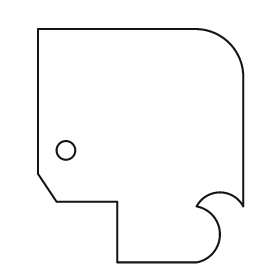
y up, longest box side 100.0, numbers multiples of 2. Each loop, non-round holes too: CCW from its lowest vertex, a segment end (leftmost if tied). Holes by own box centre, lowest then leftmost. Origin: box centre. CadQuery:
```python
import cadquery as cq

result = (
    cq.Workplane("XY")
    .moveTo(-10.0, -50.0)
    .lineTo(24.0, -50.0)
    .threePointArc((34.0, -38.0), (24.0, -26.0))
    .threePointArc((34.0, -20.0), (44.0, -26.0))
    .lineTo(44.0, 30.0)
    .threePointArc((38.0, 44.0), (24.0, 50.0))
    .lineTo(-44.0, 50.0)
    .lineTo(-44.0, -12.0)
    .lineTo(-36.0, -24.0)
    .lineTo(-10.0, -24.0)
    .close()
    .moveTo(-32.0, -2.0)
    .circle(4.0)
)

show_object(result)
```